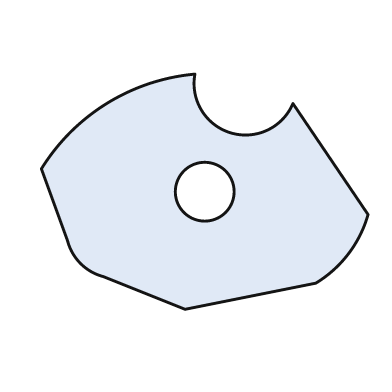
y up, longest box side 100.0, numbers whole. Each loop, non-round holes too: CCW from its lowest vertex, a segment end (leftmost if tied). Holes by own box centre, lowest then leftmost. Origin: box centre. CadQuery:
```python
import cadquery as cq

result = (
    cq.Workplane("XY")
    .moveTo(-6.0, -36.0)
    .lineTo(34.0, -28.0)
    .threePointArc((44.0, -19.0), (50.0, -7.0))
    .lineTo(27.0, 27.0)
    .threePointArc((8.0, 18.0), (-3.0, 36.0))
    .threePointArc((-30.0, 27.0), (-50.0, 7.0))
    .lineTo(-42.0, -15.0)
    .threePointArc((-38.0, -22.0), (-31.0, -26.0))
    .close()
    .moveTo(0.0, 0.0)
    .circle(9.0)
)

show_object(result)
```